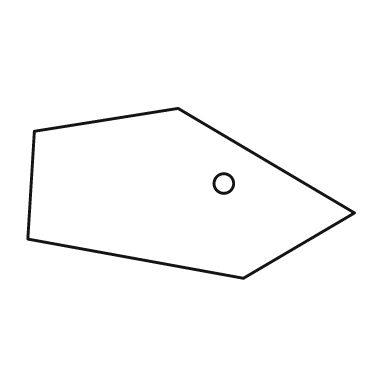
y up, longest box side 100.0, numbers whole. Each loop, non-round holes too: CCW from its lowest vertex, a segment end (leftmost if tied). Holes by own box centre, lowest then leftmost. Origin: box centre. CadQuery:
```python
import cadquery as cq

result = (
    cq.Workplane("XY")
    .moveTo(16.0, -26.0)
    .lineTo(50.0, -6.0)
    .lineTo(-4.0, 26.0)
    .lineTo(-48.0, 19.0)
    .lineTo(-50.0, -14.0)
    .close()
    .moveTo(10.0, 3.0)
    .circle(3.0)
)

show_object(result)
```